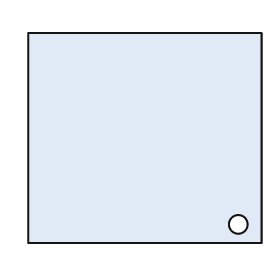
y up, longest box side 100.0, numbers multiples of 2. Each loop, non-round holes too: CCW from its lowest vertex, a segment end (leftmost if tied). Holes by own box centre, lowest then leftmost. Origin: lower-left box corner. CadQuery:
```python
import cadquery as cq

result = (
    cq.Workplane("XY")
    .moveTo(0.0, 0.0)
    .lineTo(100.0, 0.0)
    .lineTo(100.0, 90.0)
    .lineTo(0.0, 90.0)
    .close()
    .moveTo(90.0, 8.0)
    .circle(4.0)
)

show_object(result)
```